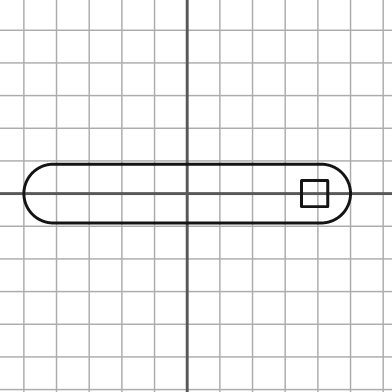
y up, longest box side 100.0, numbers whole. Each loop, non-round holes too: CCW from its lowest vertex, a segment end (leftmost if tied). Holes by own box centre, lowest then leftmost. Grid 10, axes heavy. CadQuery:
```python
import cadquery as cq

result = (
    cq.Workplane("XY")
    .moveTo(-41.0, -9.0)
    .lineTo(41.0, -9.0)
    .threePointArc((50.0, 0.0), (41.0, 9.0))
    .lineTo(-41.0, 9.0)
    .threePointArc((-50.0, 0.0), (-41.0, -9.0))
    .close()
    .moveTo(35.0, -4.0)
    .lineTo(43.0, -4.0)
    .lineTo(43.0, 4.0)
    .lineTo(35.0, 4.0)
    .close()
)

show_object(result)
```